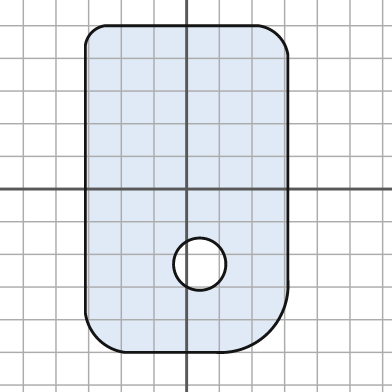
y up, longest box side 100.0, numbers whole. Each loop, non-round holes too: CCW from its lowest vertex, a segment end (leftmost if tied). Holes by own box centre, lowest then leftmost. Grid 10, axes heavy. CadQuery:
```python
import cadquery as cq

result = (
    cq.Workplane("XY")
    .moveTo(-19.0, -50.0)
    .lineTo(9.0, -50.0)
    .threePointArc((25.0, -44.0), (31.0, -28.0))
    .lineTo(31.0, 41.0)
    .threePointArc((28.0, 47.0), (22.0, 50.0))
    .lineTo(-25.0, 50.0)
    .threePointArc((-29.0, 48.0), (-31.0, 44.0))
    .lineTo(-31.0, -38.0)
    .threePointArc((-27.0, -46.0), (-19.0, -50.0))
    .close()
    .moveTo(4.0, -23.0)
    .circle(8.0)
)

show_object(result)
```